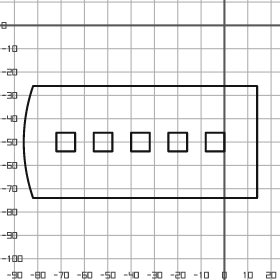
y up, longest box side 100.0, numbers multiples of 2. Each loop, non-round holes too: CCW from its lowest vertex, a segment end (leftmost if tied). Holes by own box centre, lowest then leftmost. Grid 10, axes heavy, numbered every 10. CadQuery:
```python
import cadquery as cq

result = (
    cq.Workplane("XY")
    .moveTo(-82.0, -74.0)
    .lineTo(14.0, -74.0)
    .lineTo(14.0, -26.0)
    .lineTo(-82.0, -26.0)
    .threePointArc((-86.0, -50.0), (-82.0, -74.0))
    .close()
    .moveTo(-72.0, -54.0)
    .lineTo(-64.0, -54.0)
    .lineTo(-64.0, -46.0)
    .lineTo(-72.0, -46.0)
    .close()
    .moveTo(-56.0, -54.0)
    .lineTo(-48.0, -54.0)
    .lineTo(-48.0, -46.0)
    .lineTo(-56.0, -46.0)
    .close()
    .moveTo(-40.0, -54.0)
    .lineTo(-32.0, -54.0)
    .lineTo(-32.0, -46.0)
    .lineTo(-40.0, -46.0)
    .close()
    .moveTo(-24.0, -54.0)
    .lineTo(-16.0, -54.0)
    .lineTo(-16.0, -46.0)
    .lineTo(-24.0, -46.0)
    .close()
    .moveTo(-8.0, -54.0)
    .lineTo(0.0, -54.0)
    .lineTo(0.0, -46.0)
    .lineTo(-8.0, -46.0)
    .close()
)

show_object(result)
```